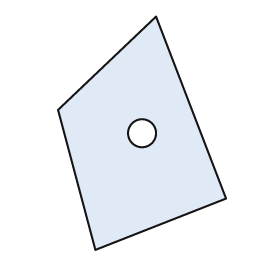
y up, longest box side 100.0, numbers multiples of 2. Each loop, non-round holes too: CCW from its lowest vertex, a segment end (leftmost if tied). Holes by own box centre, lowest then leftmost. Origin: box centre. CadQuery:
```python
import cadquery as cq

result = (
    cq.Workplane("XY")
    .moveTo(-20.0, -50.0)
    .lineTo(36.0, -28.0)
    .lineTo(6.0, 50.0)
    .lineTo(-36.0, 10.0)
    .close()
    .moveTo(0.0, 0.0)
    .circle(6.0)
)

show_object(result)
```